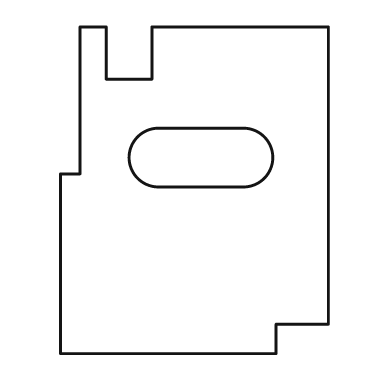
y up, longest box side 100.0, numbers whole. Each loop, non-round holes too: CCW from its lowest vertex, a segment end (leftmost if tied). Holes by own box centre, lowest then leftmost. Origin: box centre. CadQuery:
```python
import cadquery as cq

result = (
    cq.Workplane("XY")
    .moveTo(-41.0, -50.0)
    .lineTo(25.0, -50.0)
    .lineTo(25.0, -41.0)
    .lineTo(41.0, -41.0)
    .lineTo(41.0, 50.0)
    .lineTo(-13.0, 50.0)
    .lineTo(-13.0, 34.0)
    .lineTo(-27.0, 34.0)
    .lineTo(-27.0, 50.0)
    .lineTo(-35.0, 50.0)
    .lineTo(-35.0, 5.0)
    .lineTo(-41.0, 5.0)
    .close()
    .moveTo(-11.0, 1.0)
    .lineTo(15.0, 1.0)
    .threePointArc((24.0, 10.0), (15.0, 19.0))
    .lineTo(-11.0, 19.0)
    .threePointArc((-20.0, 10.0), (-11.0, 1.0))
    .close()
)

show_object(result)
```